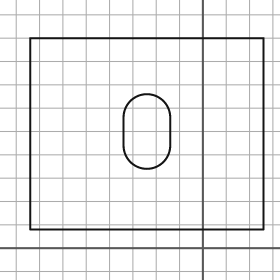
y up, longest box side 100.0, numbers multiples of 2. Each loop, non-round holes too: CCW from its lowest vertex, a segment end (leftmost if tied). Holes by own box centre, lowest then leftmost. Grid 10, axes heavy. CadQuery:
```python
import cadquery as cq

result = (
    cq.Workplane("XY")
    .moveTo(-74.0, 8.0)
    .lineTo(26.0, 8.0)
    .lineTo(26.0, 90.0)
    .lineTo(-74.0, 90.0)
    .close()
    .moveTo(-34.0, 44.0)
    .threePointArc((-24.0, 34.0), (-14.0, 44.0))
    .lineTo(-14.0, 56.0)
    .threePointArc((-24.0, 66.0), (-34.0, 56.0))
    .close()
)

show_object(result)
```